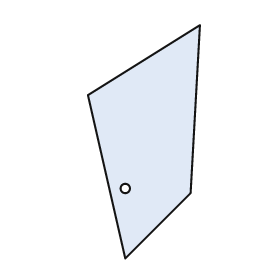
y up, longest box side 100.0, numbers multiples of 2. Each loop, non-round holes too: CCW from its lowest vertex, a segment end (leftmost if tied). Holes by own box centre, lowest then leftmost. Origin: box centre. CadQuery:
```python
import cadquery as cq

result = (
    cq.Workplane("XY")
    .moveTo(-8.0, -50.0)
    .lineTo(20.0, -22.0)
    .lineTo(24.0, 50.0)
    .lineTo(-24.0, 20.0)
    .close()
    .moveTo(-8.0, -20.0)
    .circle(2.0)
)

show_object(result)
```